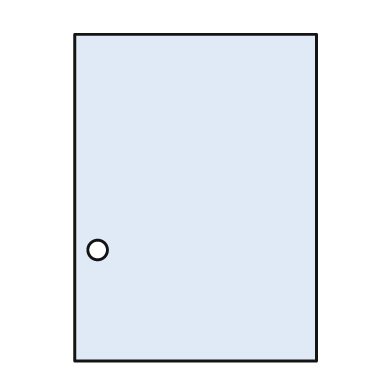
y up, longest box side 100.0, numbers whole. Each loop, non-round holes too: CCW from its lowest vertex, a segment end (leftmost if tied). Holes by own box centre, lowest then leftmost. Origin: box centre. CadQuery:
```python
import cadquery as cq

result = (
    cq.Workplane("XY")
    .moveTo(-37.0, -50.0)
    .lineTo(37.0, -50.0)
    .lineTo(37.0, 50.0)
    .lineTo(-37.0, 50.0)
    .close()
    .moveTo(-30.0, -16.0)
    .circle(3.0)
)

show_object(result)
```